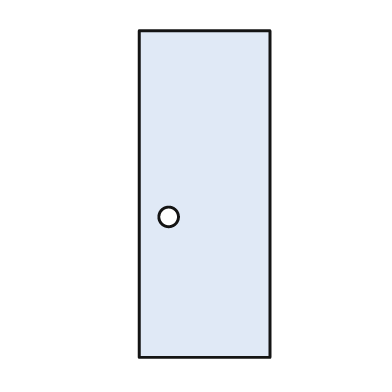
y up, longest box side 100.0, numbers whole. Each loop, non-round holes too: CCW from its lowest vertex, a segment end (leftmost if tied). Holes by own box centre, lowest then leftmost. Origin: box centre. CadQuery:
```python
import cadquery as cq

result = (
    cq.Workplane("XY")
    .moveTo(-20.0, -50.0)
    .lineTo(20.0, -50.0)
    .lineTo(20.0, 50.0)
    .lineTo(-20.0, 50.0)
    .close()
    .moveTo(-11.0, -7.0)
    .circle(3.0)
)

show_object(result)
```